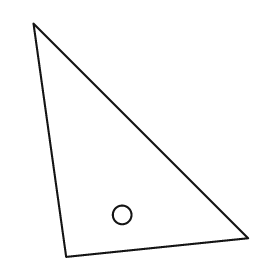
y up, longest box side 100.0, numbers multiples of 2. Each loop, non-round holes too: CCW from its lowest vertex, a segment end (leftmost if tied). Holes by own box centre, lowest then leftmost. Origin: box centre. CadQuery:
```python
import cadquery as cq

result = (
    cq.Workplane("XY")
    .moveTo(-32.0, -50.0)
    .lineTo(46.0, -42.0)
    .lineTo(-46.0, 50.0)
    .close()
    .moveTo(-8.0, -32.0)
    .circle(4.0)
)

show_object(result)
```